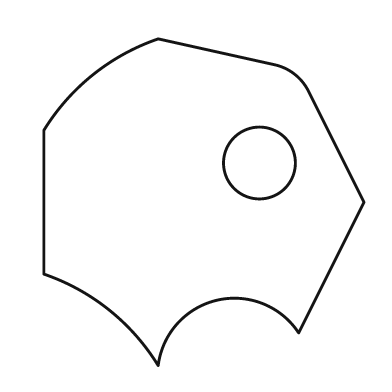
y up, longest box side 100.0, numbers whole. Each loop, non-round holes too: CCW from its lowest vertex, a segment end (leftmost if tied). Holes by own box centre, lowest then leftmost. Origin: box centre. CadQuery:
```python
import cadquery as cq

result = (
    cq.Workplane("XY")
    .moveTo(-14.0, -50.0)
    .threePointArc((4.0, -30.0), (29.0, -40.0))
    .lineTo(49.0, 0.0)
    .lineTo(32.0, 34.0)
    .threePointArc((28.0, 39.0), (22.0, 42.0))
    .lineTo(-14.0, 50.0)
    .threePointArc((-34.0, 39.0), (-49.0, 22.0))
    .lineTo(-49.0, -22.0)
    .threePointArc((-29.0, -33.0), (-14.0, -50.0))
    .close()
    .moveTo(17.0, 12.0)
    .circle(11.0)
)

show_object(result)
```